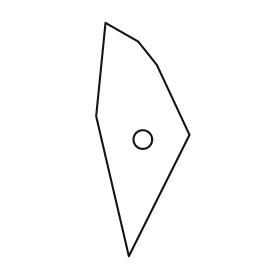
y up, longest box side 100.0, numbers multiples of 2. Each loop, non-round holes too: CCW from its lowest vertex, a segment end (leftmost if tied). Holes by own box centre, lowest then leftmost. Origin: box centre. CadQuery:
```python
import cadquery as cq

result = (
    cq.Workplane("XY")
    .moveTo(-6.0, -50.0)
    .lineTo(20.0, 2.0)
    .lineTo(6.0, 32.0)
    .lineTo(-2.0, 42.0)
    .lineTo(-16.0, 50.0)
    .lineTo(-20.0, 10.0)
    .close()
    .moveTo(0.0, 0.0)
    .circle(4.0)
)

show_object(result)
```